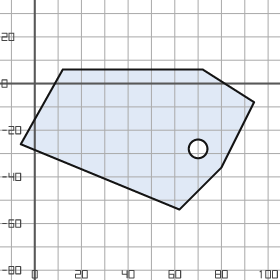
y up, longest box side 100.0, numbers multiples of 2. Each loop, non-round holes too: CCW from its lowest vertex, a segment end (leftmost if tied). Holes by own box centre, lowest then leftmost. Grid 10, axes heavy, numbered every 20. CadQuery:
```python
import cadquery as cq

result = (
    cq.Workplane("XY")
    .moveTo(62.0, -54.0)
    .lineTo(80.0, -36.0)
    .lineTo(94.0, -8.0)
    .lineTo(72.0, 6.0)
    .lineTo(12.0, 6.0)
    .lineTo(-6.0, -26.0)
    .close()
    .moveTo(70.0, -28.0)
    .circle(4.0)
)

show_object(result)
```